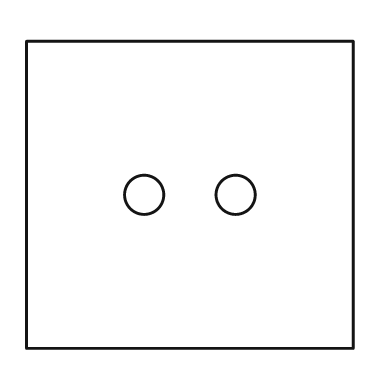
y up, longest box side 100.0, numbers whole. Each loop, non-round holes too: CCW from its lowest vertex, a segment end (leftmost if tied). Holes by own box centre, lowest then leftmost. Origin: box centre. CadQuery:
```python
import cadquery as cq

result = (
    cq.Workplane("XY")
    .moveTo(-50.0, -47.0)
    .lineTo(50.0, -47.0)
    .lineTo(50.0, 47.0)
    .lineTo(-50.0, 47.0)
    .close()
    .moveTo(-14.0, 0.0)
    .circle(6.0)
    .moveTo(14.0, 0.0)
    .circle(6.0)
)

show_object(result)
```